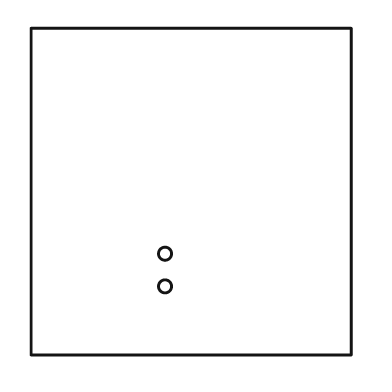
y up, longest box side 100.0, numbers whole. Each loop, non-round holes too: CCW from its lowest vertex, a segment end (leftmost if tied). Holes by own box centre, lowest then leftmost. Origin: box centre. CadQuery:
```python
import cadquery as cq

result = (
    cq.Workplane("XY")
    .moveTo(-49.0, -50.0)
    .lineTo(49.0, -50.0)
    .lineTo(49.0, 50.0)
    .lineTo(-49.0, 50.0)
    .close()
    .moveTo(-8.0, -29.0)
    .circle(2.0)
    .moveTo(-8.0, -19.0)
    .circle(2.0)
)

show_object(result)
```